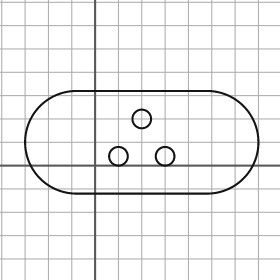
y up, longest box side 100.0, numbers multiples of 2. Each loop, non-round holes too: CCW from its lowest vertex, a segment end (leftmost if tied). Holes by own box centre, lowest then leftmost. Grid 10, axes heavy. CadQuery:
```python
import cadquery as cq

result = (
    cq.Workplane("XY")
    .moveTo(-8.0, -12.0)
    .lineTo(48.0, -12.0)
    .threePointArc((70.0, 10.0), (48.0, 32.0))
    .lineTo(-8.0, 32.0)
    .threePointArc((-30.0, 10.0), (-8.0, -12.0))
    .close()
    .moveTo(10.0, 4.0)
    .circle(4.0)
    .moveTo(30.0, 4.0)
    .circle(4.0)
    .moveTo(20.0, 20.0)
    .circle(4.0)
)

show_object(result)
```